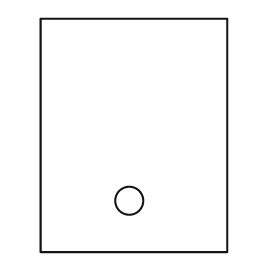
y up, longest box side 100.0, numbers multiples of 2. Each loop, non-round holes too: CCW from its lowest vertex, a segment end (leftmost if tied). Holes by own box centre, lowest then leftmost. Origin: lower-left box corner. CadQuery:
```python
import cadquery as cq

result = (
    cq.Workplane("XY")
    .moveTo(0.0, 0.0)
    .lineTo(80.0, 0.0)
    .lineTo(80.0, 100.0)
    .lineTo(0.0, 100.0)
    .close()
    .moveTo(38.0, 22.0)
    .circle(6.0)
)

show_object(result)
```